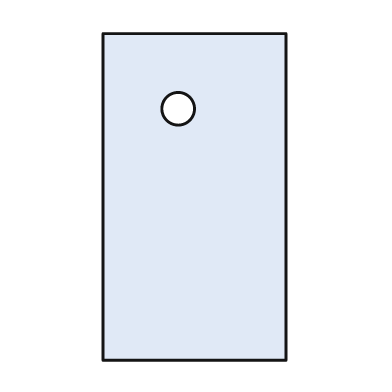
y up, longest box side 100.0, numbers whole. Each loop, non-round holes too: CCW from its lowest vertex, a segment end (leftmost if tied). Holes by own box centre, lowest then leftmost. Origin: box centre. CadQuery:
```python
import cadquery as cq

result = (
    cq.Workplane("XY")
    .moveTo(-28.0, -50.0)
    .lineTo(28.0, -50.0)
    .lineTo(28.0, 50.0)
    .lineTo(-28.0, 50.0)
    .close()
    .moveTo(-5.0, 27.0)
    .circle(5.0)
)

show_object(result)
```